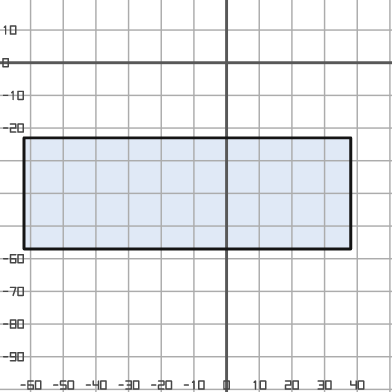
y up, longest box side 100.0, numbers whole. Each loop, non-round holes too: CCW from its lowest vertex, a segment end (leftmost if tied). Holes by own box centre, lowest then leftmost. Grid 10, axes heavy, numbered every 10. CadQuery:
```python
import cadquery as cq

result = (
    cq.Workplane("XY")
    .moveTo(-62.0, -57.0)
    .lineTo(38.0, -57.0)
    .lineTo(38.0, -23.0)
    .lineTo(-62.0, -23.0)
    .close()
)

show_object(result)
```